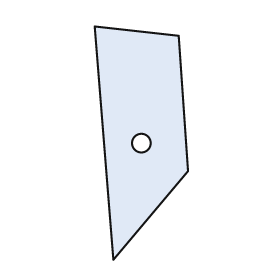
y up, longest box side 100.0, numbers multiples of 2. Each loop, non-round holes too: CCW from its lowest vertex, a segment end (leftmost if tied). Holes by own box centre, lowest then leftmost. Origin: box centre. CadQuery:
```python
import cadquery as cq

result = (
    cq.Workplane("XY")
    .moveTo(-12.0, -50.0)
    .lineTo(20.0, -12.0)
    .lineTo(16.0, 46.0)
    .lineTo(-20.0, 50.0)
    .close()
    .moveTo(0.0, 0.0)
    .circle(4.0)
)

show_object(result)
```